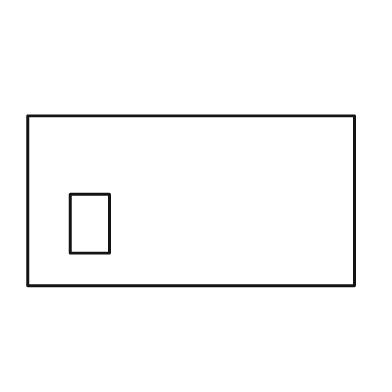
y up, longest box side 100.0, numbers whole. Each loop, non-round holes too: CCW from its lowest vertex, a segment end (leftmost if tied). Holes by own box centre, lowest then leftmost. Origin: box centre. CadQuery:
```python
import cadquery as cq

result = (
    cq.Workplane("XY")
    .moveTo(-50.0, -26.0)
    .lineTo(50.0, -26.0)
    .lineTo(50.0, 26.0)
    .lineTo(-50.0, 26.0)
    .close()
    .moveTo(-37.0, -16.0)
    .lineTo(-25.0, -16.0)
    .lineTo(-25.0, 2.0)
    .lineTo(-37.0, 2.0)
    .close()
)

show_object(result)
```